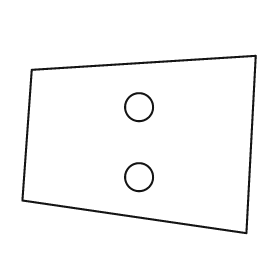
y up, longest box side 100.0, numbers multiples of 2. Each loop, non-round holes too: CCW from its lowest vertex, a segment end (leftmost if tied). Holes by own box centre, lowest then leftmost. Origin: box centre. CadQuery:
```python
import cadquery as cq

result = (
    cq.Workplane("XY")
    .moveTo(46.0, -38.0)
    .lineTo(50.0, 38.0)
    .lineTo(-46.0, 32.0)
    .lineTo(-50.0, -24.0)
    .close()
    .moveTo(0.0, -14.0)
    .circle(6.0)
    .moveTo(0.0, 16.0)
    .circle(6.0)
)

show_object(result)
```